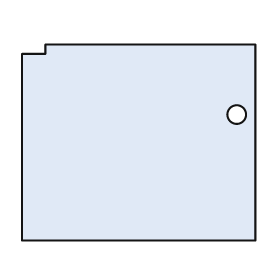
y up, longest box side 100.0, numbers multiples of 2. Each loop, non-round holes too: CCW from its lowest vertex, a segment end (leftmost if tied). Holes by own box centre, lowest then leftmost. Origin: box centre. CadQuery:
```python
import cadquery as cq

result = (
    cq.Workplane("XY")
    .moveTo(-50.0, -42.0)
    .lineTo(50.0, -42.0)
    .lineTo(50.0, 42.0)
    .lineTo(-40.0, 42.0)
    .lineTo(-40.0, 38.0)
    .lineTo(-50.0, 38.0)
    .close()
    .moveTo(42.0, 12.0)
    .circle(4.0)
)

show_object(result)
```